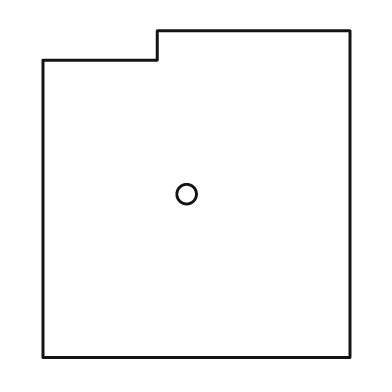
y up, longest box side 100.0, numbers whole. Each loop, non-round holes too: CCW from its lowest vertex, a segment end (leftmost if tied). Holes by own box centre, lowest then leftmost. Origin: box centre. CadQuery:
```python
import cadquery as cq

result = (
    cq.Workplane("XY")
    .moveTo(-47.0, -50.0)
    .lineTo(47.0, -50.0)
    .lineTo(47.0, 50.0)
    .lineTo(-12.0, 50.0)
    .lineTo(-12.0, 41.0)
    .lineTo(-47.0, 41.0)
    .close()
    .moveTo(-3.0, 0.0)
    .circle(3.0)
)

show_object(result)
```